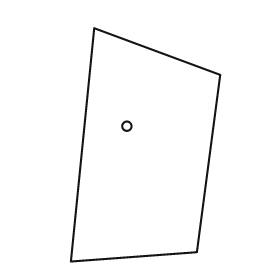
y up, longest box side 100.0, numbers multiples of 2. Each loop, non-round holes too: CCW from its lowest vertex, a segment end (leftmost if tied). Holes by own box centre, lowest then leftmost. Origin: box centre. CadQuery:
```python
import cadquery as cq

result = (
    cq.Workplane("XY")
    .moveTo(-32.0, -50.0)
    .lineTo(22.0, -46.0)
    .lineTo(32.0, 30.0)
    .lineTo(-22.0, 50.0)
    .close()
    .moveTo(-8.0, 8.0)
    .circle(2.0)
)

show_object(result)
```